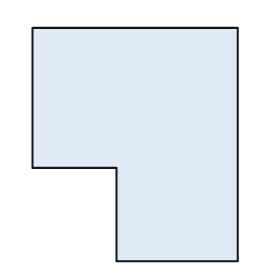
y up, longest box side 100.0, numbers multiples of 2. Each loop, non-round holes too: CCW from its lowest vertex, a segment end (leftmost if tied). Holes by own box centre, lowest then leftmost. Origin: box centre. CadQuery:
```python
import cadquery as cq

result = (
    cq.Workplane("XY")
    .moveTo(-8.0, -50.0)
    .lineTo(44.0, -50.0)
    .lineTo(44.0, 50.0)
    .lineTo(-44.0, 50.0)
    .lineTo(-44.0, -10.0)
    .lineTo(-8.0, -10.0)
    .close()
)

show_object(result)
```